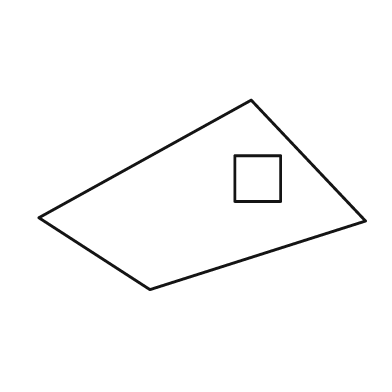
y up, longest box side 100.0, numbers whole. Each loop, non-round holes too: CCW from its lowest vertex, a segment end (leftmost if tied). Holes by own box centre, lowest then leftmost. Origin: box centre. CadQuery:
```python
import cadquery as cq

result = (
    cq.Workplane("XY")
    .moveTo(-16.0, -29.0)
    .lineTo(50.0, -8.0)
    .lineTo(15.0, 29.0)
    .lineTo(-50.0, -7.0)
    .close()
    .moveTo(10.0, -2.0)
    .lineTo(24.0, -2.0)
    .lineTo(24.0, 12.0)
    .lineTo(10.0, 12.0)
    .close()
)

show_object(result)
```